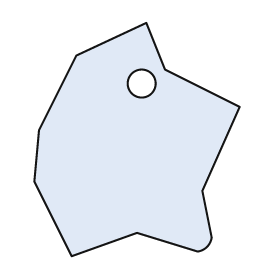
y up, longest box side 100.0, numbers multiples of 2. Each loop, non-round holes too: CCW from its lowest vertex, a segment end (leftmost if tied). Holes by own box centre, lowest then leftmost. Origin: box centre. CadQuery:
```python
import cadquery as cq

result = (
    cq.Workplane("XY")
    .moveTo(-28.0, -50.0)
    .lineTo(0.0, -40.0)
    .lineTo(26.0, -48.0)
    .threePointArc((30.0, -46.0), (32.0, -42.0))
    .lineTo(28.0, -22.0)
    .lineTo(44.0, 14.0)
    .lineTo(12.0, 30.0)
    .lineTo(4.0, 50.0)
    .lineTo(-26.0, 36.0)
    .lineTo(-42.0, 4.0)
    .lineTo(-44.0, -18.0)
    .close()
    .moveTo(2.0, 24.0)
    .circle(6.0)
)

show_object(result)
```